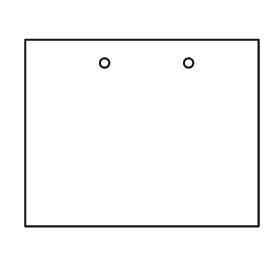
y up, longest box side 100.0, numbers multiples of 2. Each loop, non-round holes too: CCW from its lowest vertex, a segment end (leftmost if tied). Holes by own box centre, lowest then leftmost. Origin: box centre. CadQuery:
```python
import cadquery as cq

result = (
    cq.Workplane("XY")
    .moveTo(-50.0, -40.0)
    .lineTo(50.0, -40.0)
    .lineTo(50.0, 40.0)
    .lineTo(-50.0, 40.0)
    .close()
    .moveTo(-16.0, 30.0)
    .circle(2.0)
    .moveTo(20.0, 30.0)
    .circle(2.0)
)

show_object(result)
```